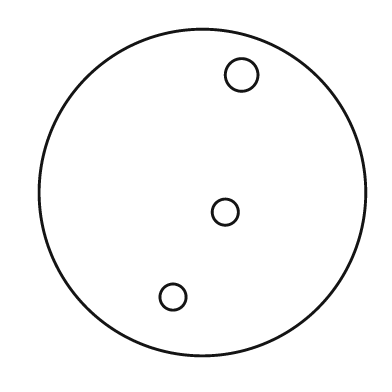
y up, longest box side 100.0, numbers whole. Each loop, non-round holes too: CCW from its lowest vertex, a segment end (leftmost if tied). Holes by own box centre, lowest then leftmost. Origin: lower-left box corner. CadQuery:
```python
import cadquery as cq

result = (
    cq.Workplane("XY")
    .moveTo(50.0, 50.0)
    .circle(50.0)
    .moveTo(41.0, 18.0)
    .circle(4.0)
    .moveTo(57.0, 44.0)
    .circle(4.0)
    .moveTo(62.0, 86.0)
    .circle(5.0)
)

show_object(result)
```